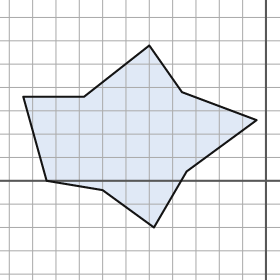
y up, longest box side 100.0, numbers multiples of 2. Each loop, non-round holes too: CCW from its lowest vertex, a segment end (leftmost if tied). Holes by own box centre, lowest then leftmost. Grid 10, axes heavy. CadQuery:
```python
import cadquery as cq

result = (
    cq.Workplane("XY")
    .moveTo(-48.0, -20.0)
    .lineTo(-34.0, 4.0)
    .lineTo(-4.0, 26.0)
    .lineTo(-36.0, 38.0)
    .lineTo(-50.0, 58.0)
    .lineTo(-78.0, 36.0)
    .lineTo(-104.0, 36.0)
    .lineTo(-94.0, 0.0)
    .lineTo(-70.0, -4.0)
    .close()
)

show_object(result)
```